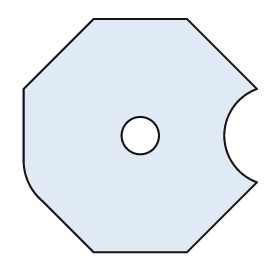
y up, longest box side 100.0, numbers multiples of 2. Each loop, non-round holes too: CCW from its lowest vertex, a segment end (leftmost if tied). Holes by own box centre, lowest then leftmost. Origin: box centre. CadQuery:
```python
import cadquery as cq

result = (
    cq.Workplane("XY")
    .moveTo(-20.0, -50.0)
    .lineTo(20.0, -50.0)
    .lineTo(50.0, -20.0)
    .threePointArc((36.0, 0.0), (50.0, 20.0))
    .lineTo(20.0, 50.0)
    .lineTo(-20.0, 50.0)
    .lineTo(-50.0, 20.0)
    .lineTo(-50.0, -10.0)
    .threePointArc((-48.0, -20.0), (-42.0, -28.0))
    .close()
    .moveTo(0.0, 0.0)
    .circle(8.0)
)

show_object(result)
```